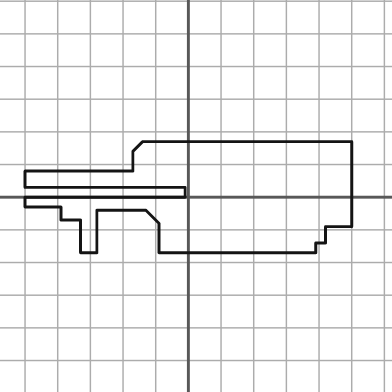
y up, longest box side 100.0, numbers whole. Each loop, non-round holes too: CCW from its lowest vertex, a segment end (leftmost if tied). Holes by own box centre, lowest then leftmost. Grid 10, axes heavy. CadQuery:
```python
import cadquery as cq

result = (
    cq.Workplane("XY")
    .moveTo(-33.0, -17.0)
    .lineTo(-28.0, -17.0)
    .lineTo(-28.0, -4.0)
    .lineTo(-13.0, -4.0)
    .lineTo(-9.0, -8.0)
    .lineTo(-9.0, -17.0)
    .lineTo(39.0, -17.0)
    .lineTo(39.0, -14.0)
    .lineTo(42.0, -14.0)
    .lineTo(42.0, -9.0)
    .lineTo(50.0, -9.0)
    .lineTo(50.0, 17.0)
    .lineTo(-14.0, 17.0)
    .lineTo(-17.0, 14.0)
    .lineTo(-17.0, 8.0)
    .lineTo(-50.0, 8.0)
    .lineTo(-50.0, 3.0)
    .lineTo(-1.0, 3.0)
    .lineTo(-1.0, 0.0)
    .lineTo(-50.0, 0.0)
    .lineTo(-50.0, -3.0)
    .lineTo(-39.0, -3.0)
    .lineTo(-39.0, -7.0)
    .lineTo(-33.0, -7.0)
    .close()
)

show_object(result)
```